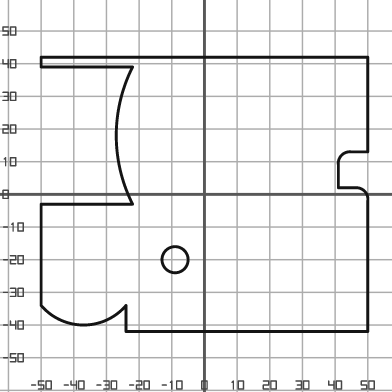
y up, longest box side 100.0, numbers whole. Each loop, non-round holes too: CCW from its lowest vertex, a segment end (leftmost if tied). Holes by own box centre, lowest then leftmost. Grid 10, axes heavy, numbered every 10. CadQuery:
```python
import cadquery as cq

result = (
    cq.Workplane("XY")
    .moveTo(-24.0, -42.0)
    .lineTo(50.0, -42.0)
    .lineTo(50.0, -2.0)
    .threePointArc((49.0, 1.0), (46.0, 2.0))
    .lineTo(41.0, 2.0)
    .lineTo(41.0, 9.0)
    .threePointArc((42.0, 12.0), (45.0, 13.0))
    .lineTo(50.0, 13.0)
    .lineTo(50.0, 42.0)
    .lineTo(-50.0, 42.0)
    .lineTo(-50.0, 39.0)
    .lineTo(-22.0, 39.0)
    .threePointArc((-27.0, 18.0), (-22.0, -3.0))
    .lineTo(-50.0, -3.0)
    .lineTo(-50.0, -34.0)
    .threePointArc((-37.0, -40.0), (-24.0, -34.0))
    .close()
    .moveTo(-9.0, -20.0)
    .circle(4.0)
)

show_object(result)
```